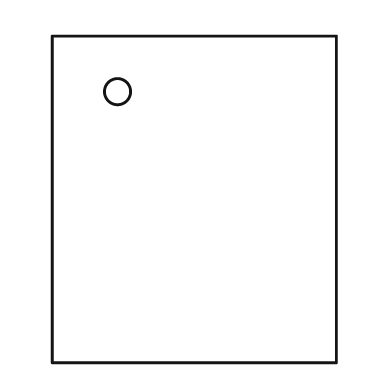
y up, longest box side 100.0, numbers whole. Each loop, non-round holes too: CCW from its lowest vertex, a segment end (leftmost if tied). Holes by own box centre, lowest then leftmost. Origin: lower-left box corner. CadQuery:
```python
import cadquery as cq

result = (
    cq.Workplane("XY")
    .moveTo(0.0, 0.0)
    .lineTo(87.0, 0.0)
    .lineTo(87.0, 100.0)
    .lineTo(0.0, 100.0)
    .close()
    .moveTo(20.0, 83.0)
    .circle(4.0)
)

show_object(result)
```